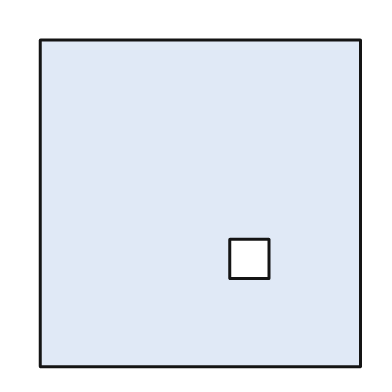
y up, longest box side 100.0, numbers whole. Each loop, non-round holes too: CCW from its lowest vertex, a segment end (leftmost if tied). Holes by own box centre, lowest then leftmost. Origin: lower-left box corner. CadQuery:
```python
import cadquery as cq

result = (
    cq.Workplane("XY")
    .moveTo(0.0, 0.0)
    .lineTo(98.0, 0.0)
    .lineTo(98.0, 100.0)
    .lineTo(0.0, 100.0)
    .close()
    .moveTo(58.0, 27.0)
    .lineTo(70.0, 27.0)
    .lineTo(70.0, 39.0)
    .lineTo(58.0, 39.0)
    .close()
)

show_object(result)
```